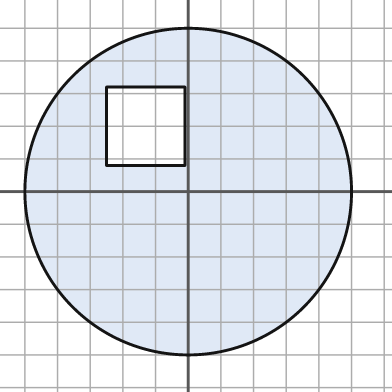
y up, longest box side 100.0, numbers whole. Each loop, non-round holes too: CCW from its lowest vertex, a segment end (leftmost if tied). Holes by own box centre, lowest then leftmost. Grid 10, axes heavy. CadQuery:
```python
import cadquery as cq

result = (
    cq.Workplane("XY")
    .moveTo(0.0, 0.0)
    .circle(50.0)
    .moveTo(-25.0, 8.0)
    .lineTo(-1.0, 8.0)
    .lineTo(-1.0, 32.0)
    .lineTo(-25.0, 32.0)
    .close()
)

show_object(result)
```